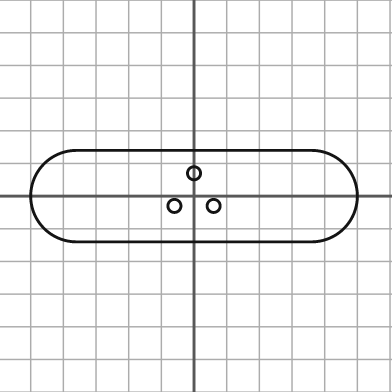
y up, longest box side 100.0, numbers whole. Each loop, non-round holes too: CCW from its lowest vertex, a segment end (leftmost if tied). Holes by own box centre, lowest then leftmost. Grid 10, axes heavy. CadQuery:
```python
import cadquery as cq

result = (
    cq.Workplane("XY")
    .moveTo(-36.0, -14.0)
    .lineTo(36.0, -14.0)
    .threePointArc((50.0, 0.0), (36.0, 14.0))
    .lineTo(-36.0, 14.0)
    .threePointArc((-50.0, 0.0), (-36.0, -14.0))
    .close()
    .moveTo(-6.0, -3.0)
    .circle(2.0)
    .moveTo(6.0, -3.0)
    .circle(2.0)
    .moveTo(0.0, 7.0)
    .circle(2.0)
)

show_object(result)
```